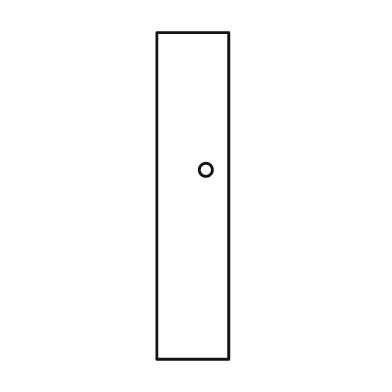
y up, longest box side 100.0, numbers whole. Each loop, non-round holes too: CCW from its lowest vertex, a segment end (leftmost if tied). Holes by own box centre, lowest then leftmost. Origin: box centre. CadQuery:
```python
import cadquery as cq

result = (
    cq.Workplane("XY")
    .moveTo(-11.0, -50.0)
    .lineTo(11.0, -50.0)
    .lineTo(11.0, 50.0)
    .lineTo(-11.0, 50.0)
    .close()
    .moveTo(4.0, 8.0)
    .circle(2.0)
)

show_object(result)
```